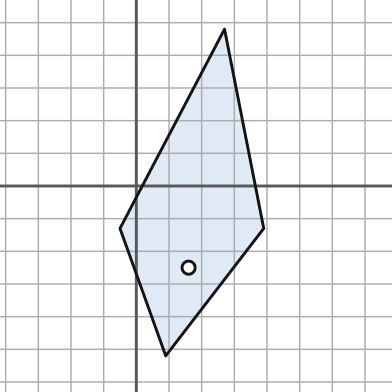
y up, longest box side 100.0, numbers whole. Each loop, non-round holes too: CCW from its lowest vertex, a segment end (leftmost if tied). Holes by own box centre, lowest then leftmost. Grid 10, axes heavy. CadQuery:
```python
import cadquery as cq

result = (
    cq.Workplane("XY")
    .moveTo(9.0, -52.0)
    .lineTo(39.0, -13.0)
    .lineTo(27.0, 48.0)
    .lineTo(-5.0, -13.0)
    .close()
    .moveTo(16.0, -25.0)
    .circle(2.0)
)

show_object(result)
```